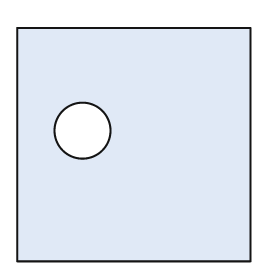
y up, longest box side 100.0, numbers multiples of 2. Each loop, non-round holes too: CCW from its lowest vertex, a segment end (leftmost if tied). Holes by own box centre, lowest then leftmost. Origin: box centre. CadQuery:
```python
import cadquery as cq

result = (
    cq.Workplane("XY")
    .moveTo(-50.0, -50.0)
    .lineTo(50.0, -50.0)
    .lineTo(50.0, 50.0)
    .lineTo(-50.0, 50.0)
    .close()
    .moveTo(-22.0, 6.0)
    .circle(12.0)
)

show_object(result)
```